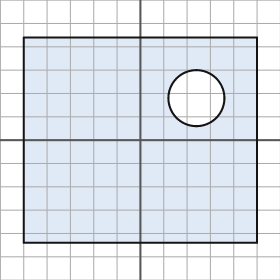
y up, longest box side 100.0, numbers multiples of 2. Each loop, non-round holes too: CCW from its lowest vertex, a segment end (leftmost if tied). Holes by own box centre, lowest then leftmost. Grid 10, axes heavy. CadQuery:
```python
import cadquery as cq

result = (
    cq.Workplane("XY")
    .moveTo(-50.0, -44.0)
    .lineTo(50.0, -44.0)
    .lineTo(50.0, 44.0)
    .lineTo(-50.0, 44.0)
    .close()
    .moveTo(24.0, 18.0)
    .circle(12.0)
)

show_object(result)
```